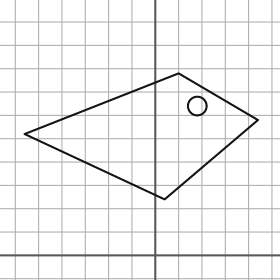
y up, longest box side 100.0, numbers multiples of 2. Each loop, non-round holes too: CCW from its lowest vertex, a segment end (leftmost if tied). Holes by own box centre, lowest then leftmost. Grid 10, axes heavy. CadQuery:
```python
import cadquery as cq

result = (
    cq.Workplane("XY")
    .moveTo(4.0, 24.0)
    .lineTo(44.0, 58.0)
    .lineTo(10.0, 78.0)
    .lineTo(-56.0, 52.0)
    .close()
    .moveTo(18.0, 64.0)
    .circle(4.0)
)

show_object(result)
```